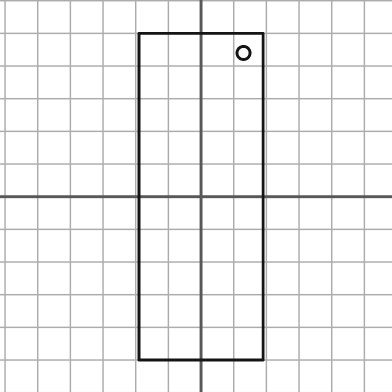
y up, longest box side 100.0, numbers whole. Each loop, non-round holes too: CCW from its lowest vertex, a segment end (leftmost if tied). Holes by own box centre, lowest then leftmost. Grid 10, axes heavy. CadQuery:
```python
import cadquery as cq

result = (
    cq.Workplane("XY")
    .moveTo(-19.0, -50.0)
    .lineTo(19.0, -50.0)
    .lineTo(19.0, 50.0)
    .lineTo(-19.0, 50.0)
    .close()
    .moveTo(13.0, 44.0)
    .circle(2.0)
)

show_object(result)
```